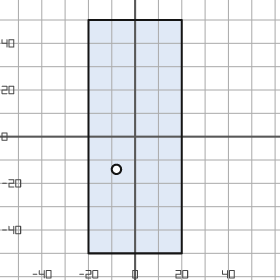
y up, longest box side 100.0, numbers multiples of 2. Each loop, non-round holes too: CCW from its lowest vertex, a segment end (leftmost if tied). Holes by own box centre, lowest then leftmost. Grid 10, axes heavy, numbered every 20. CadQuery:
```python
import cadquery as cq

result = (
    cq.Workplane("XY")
    .moveTo(-20.0, -50.0)
    .lineTo(20.0, -50.0)
    .lineTo(20.0, 50.0)
    .lineTo(-20.0, 50.0)
    .close()
    .moveTo(-8.0, -14.0)
    .circle(2.0)
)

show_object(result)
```